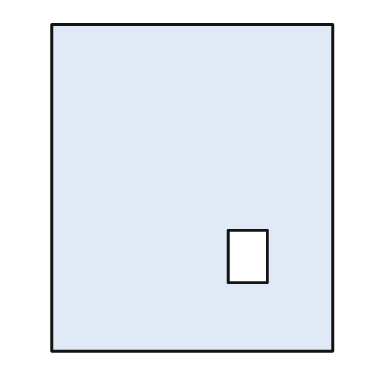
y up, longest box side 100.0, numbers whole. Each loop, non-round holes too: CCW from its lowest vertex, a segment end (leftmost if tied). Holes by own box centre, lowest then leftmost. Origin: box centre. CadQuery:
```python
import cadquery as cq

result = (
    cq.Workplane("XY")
    .moveTo(-43.0, -50.0)
    .lineTo(43.0, -50.0)
    .lineTo(43.0, 50.0)
    .lineTo(-43.0, 50.0)
    .close()
    .moveTo(11.0, -29.0)
    .lineTo(23.0, -29.0)
    .lineTo(23.0, -13.0)
    .lineTo(11.0, -13.0)
    .close()
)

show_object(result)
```